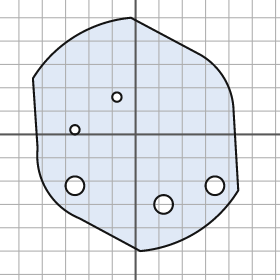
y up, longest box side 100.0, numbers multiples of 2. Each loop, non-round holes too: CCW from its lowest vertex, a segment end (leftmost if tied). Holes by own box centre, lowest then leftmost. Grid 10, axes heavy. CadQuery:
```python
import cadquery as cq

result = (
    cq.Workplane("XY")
    .moveTo(2.0, -50.0)
    .threePointArc((26.0, -42.0), (44.0, -24.0))
    .lineTo(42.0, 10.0)
    .threePointArc((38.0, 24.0), (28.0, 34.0))
    .lineTo(-2.0, 50.0)
    .threePointArc((-26.0, 42.0), (-44.0, 24.0))
    .lineTo(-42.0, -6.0)
    .threePointArc((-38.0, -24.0), (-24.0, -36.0))
    .close()
    .moveTo(12.0, -30.0)
    .circle(4.0)
    .moveTo(-26.0, -22.0)
    .circle(4.0)
    .moveTo(34.0, -22.0)
    .circle(4.0)
    .moveTo(-26.0, 2.0)
    .circle(2.0)
    .moveTo(-8.0, 16.0)
    .circle(2.0)
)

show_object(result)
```